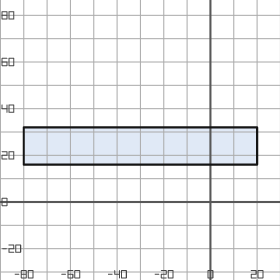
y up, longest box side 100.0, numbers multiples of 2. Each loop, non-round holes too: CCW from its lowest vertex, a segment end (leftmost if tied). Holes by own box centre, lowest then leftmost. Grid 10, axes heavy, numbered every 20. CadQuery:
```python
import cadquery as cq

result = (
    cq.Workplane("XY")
    .moveTo(-80.0, 16.0)
    .lineTo(20.0, 16.0)
    .lineTo(20.0, 32.0)
    .lineTo(-80.0, 32.0)
    .close()
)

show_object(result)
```